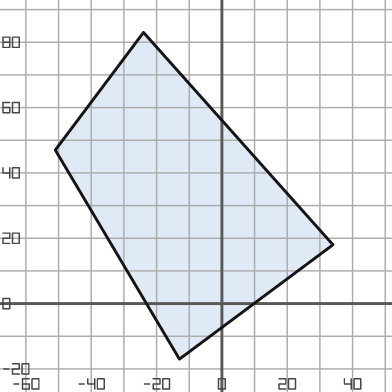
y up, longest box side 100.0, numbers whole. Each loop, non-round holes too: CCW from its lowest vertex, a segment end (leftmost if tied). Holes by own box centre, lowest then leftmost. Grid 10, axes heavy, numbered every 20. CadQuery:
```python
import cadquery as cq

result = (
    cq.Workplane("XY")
    .moveTo(-13.0, -17.0)
    .lineTo(34.0, 18.0)
    .lineTo(-24.0, 83.0)
    .lineTo(-51.0, 47.0)
    .close()
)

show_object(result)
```